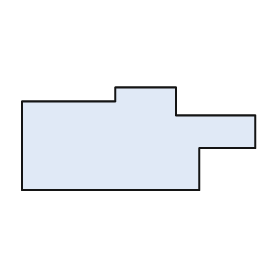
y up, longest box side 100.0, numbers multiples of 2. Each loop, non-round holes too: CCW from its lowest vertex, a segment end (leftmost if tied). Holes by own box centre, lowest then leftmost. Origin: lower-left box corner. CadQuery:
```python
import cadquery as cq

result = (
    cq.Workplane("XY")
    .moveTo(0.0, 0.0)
    .lineTo(76.0, 0.0)
    .lineTo(76.0, 18.0)
    .lineTo(100.0, 18.0)
    .lineTo(100.0, 32.0)
    .lineTo(66.0, 32.0)
    .lineTo(66.0, 44.0)
    .lineTo(40.0, 44.0)
    .lineTo(40.0, 38.0)
    .lineTo(0.0, 38.0)
    .close()
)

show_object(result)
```